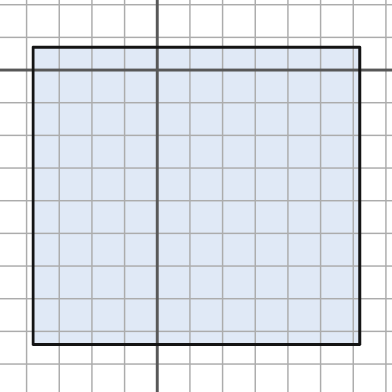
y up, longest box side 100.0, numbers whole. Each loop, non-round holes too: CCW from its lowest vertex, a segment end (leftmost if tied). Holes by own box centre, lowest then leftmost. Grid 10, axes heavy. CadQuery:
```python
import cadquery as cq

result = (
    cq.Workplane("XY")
    .moveTo(-38.0, -84.0)
    .lineTo(62.0, -84.0)
    .lineTo(62.0, 7.0)
    .lineTo(-38.0, 7.0)
    .close()
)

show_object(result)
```